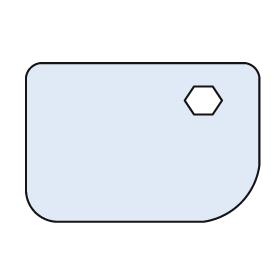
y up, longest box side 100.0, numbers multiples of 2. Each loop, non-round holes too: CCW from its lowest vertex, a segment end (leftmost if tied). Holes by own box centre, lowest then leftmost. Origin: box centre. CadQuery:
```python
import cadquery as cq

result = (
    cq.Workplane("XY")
    .moveTo(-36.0, -34.0)
    .lineTo(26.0, -34.0)
    .threePointArc((42.0, -26.0), (50.0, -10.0))
    .lineTo(50.0, 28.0)
    .threePointArc((48.0, 32.0), (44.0, 34.0))
    .lineTo(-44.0, 34.0)
    .threePointArc((-48.0, 32.0), (-50.0, 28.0))
    .lineTo(-50.0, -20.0)
    .threePointArc((-46.0, -30.0), (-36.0, -34.0))
    .close()
    .moveTo(22.0, 12.0)
    .lineTo(30.0, 12.0)
    .lineTo(34.0, 18.0)
    .lineTo(30.0, 24.0)
    .lineTo(22.0, 24.0)
    .lineTo(18.0, 18.0)
    .close()
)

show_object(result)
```